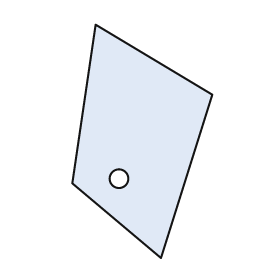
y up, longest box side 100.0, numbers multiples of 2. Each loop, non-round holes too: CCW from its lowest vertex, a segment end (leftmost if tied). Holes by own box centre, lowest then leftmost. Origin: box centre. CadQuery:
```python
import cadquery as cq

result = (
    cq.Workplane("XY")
    .moveTo(8.0, -50.0)
    .lineTo(30.0, 20.0)
    .lineTo(-20.0, 50.0)
    .lineTo(-30.0, -18.0)
    .close()
    .moveTo(-10.0, -16.0)
    .circle(4.0)
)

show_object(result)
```